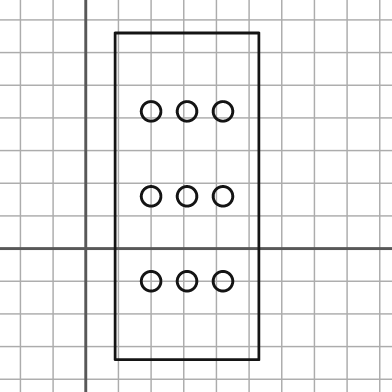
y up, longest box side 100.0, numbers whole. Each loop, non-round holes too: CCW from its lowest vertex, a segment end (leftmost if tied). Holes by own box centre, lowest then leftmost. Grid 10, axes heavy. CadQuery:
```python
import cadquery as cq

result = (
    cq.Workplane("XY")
    .moveTo(9.0, -34.0)
    .lineTo(53.0, -34.0)
    .lineTo(53.0, 66.0)
    .lineTo(9.0, 66.0)
    .close()
    .moveTo(20.0, -10.0)
    .circle(3.0)
    .moveTo(31.0, -10.0)
    .circle(3.0)
    .moveTo(42.0, -10.0)
    .circle(3.0)
    .moveTo(20.0, 16.0)
    .circle(3.0)
    .moveTo(31.0, 16.0)
    .circle(3.0)
    .moveTo(42.0, 16.0)
    .circle(3.0)
    .moveTo(20.0, 42.0)
    .circle(3.0)
    .moveTo(31.0, 42.0)
    .circle(3.0)
    .moveTo(42.0, 42.0)
    .circle(3.0)
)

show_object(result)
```